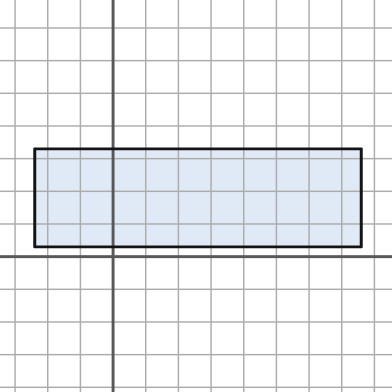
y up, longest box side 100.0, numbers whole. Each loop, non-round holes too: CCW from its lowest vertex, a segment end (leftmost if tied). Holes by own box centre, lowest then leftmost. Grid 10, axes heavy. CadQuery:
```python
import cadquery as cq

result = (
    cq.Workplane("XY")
    .moveTo(-24.0, 3.0)
    .lineTo(76.0, 3.0)
    .lineTo(76.0, 33.0)
    .lineTo(-24.0, 33.0)
    .close()
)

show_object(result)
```